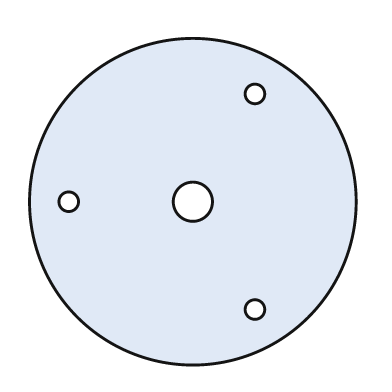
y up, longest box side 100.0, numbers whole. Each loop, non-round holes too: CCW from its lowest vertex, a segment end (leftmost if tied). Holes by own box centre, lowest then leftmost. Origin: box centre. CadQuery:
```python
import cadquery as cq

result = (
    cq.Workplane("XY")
    .moveTo(0.0, 0.0)
    .circle(50.0)
    .moveTo(19.0, -33.0)
    .circle(3.0)
    .moveTo(-38.0, 0.0)
    .circle(3.0)
    .moveTo(0.0, 0.0)
    .circle(6.0)
    .moveTo(19.0, 33.0)
    .circle(3.0)
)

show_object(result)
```